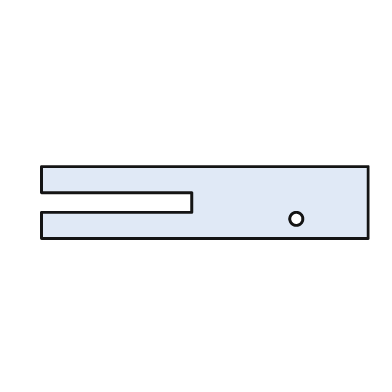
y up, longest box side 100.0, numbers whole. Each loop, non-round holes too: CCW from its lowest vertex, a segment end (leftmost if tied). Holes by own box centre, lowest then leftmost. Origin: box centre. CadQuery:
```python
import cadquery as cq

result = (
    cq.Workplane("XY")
    .moveTo(-50.0, -11.0)
    .lineTo(50.0, -11.0)
    .lineTo(50.0, 11.0)
    .lineTo(-50.0, 11.0)
    .lineTo(-50.0, 3.0)
    .lineTo(-4.0, 3.0)
    .lineTo(-4.0, -3.0)
    .lineTo(-50.0, -3.0)
    .close()
    .moveTo(28.0, -5.0)
    .circle(2.0)
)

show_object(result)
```